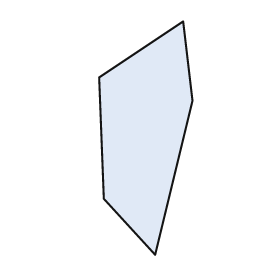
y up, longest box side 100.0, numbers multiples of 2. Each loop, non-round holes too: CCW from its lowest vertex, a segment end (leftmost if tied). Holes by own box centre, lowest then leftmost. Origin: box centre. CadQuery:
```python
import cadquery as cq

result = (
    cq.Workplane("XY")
    .moveTo(4.0, -50.0)
    .lineTo(20.0, 16.0)
    .lineTo(16.0, 50.0)
    .lineTo(-20.0, 26.0)
    .lineTo(-18.0, -26.0)
    .close()
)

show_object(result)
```